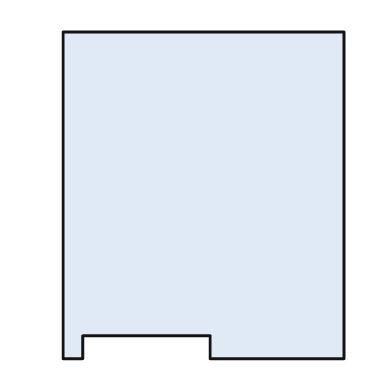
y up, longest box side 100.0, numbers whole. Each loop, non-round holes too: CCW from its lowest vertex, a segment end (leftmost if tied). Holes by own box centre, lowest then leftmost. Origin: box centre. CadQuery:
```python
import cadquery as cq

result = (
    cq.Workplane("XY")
    .moveTo(-43.0, -50.0)
    .lineTo(-37.0, -50.0)
    .lineTo(-37.0, -43.0)
    .lineTo(2.0, -43.0)
    .lineTo(2.0, -50.0)
    .lineTo(43.0, -50.0)
    .lineTo(43.0, 50.0)
    .lineTo(-43.0, 50.0)
    .close()
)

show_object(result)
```